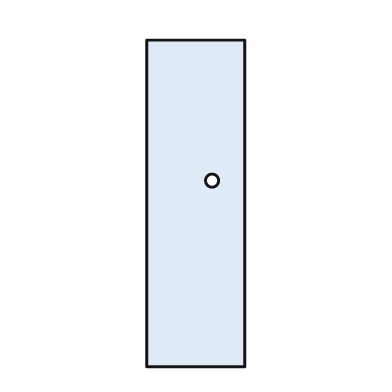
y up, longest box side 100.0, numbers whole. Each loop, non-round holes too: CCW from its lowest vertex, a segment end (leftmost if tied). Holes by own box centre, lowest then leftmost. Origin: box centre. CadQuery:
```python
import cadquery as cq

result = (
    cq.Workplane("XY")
    .moveTo(-15.0, -50.0)
    .lineTo(15.0, -50.0)
    .lineTo(15.0, 50.0)
    .lineTo(-15.0, 50.0)
    .close()
    .moveTo(5.0, 7.0)
    .circle(2.0)
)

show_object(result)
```